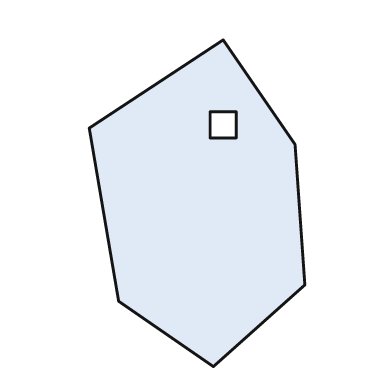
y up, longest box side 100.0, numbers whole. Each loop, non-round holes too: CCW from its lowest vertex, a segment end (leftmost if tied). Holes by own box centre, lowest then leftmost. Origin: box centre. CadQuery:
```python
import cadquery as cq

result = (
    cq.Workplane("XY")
    .moveTo(5.0, -50.0)
    .lineTo(33.0, -25.0)
    .lineTo(30.0, 18.0)
    .lineTo(8.0, 50.0)
    .lineTo(-33.0, 23.0)
    .lineTo(-24.0, -30.0)
    .close()
    .moveTo(4.0, 20.0)
    .lineTo(12.0, 20.0)
    .lineTo(12.0, 28.0)
    .lineTo(4.0, 28.0)
    .close()
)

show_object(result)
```